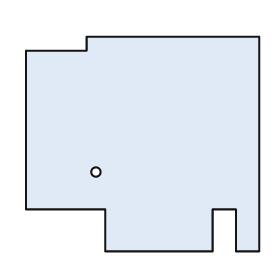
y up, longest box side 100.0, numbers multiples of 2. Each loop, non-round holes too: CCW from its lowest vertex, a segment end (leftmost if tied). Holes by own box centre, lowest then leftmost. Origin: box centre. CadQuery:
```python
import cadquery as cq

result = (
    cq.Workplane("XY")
    .moveTo(-16.0, -46.0)
    .lineTo(30.0, -46.0)
    .lineTo(30.0, -28.0)
    .lineTo(40.0, -28.0)
    .lineTo(40.0, -46.0)
    .lineTo(50.0, -46.0)
    .lineTo(50.0, 46.0)
    .lineTo(-24.0, 46.0)
    .lineTo(-24.0, 40.0)
    .lineTo(-50.0, 40.0)
    .lineTo(-50.0, -28.0)
    .lineTo(-16.0, -28.0)
    .close()
    .moveTo(-20.0, -12.0)
    .circle(2.0)
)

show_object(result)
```